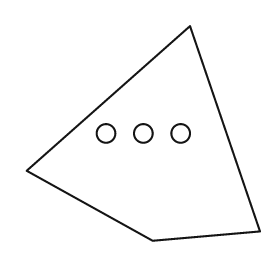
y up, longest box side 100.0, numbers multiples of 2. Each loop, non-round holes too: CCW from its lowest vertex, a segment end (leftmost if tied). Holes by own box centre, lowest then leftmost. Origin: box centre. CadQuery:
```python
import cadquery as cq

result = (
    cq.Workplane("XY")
    .moveTo(4.0, -46.0)
    .lineTo(50.0, -42.0)
    .lineTo(20.0, 46.0)
    .lineTo(-50.0, -16.0)
    .close()
    .moveTo(-16.0, 0.0)
    .circle(4.0)
    .moveTo(0.0, 0.0)
    .circle(4.0)
    .moveTo(16.0, 0.0)
    .circle(4.0)
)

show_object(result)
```